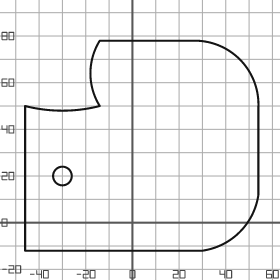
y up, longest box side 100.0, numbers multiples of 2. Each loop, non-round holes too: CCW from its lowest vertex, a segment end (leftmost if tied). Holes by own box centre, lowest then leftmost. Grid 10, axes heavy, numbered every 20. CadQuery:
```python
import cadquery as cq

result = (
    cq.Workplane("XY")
    .moveTo(-46.0, -12.0)
    .lineTo(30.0, -12.0)
    .threePointArc((46.0, -4.0), (54.0, 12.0))
    .lineTo(54.0, 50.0)
    .threePointArc((46.0, 70.0), (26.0, 78.0))
    .lineTo(-14.0, 78.0)
    .threePointArc((-18.0, 64.0), (-14.0, 50.0))
    .threePointArc((-30.0, 48.0), (-46.0, 50.0))
    .close()
    .moveTo(-30.0, 20.0)
    .circle(4.0)
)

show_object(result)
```